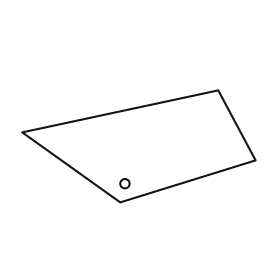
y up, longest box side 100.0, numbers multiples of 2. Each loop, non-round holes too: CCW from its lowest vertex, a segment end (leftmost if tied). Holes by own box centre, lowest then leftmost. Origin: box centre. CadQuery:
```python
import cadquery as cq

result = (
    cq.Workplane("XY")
    .moveTo(-8.0, -24.0)
    .lineTo(50.0, -6.0)
    .lineTo(34.0, 24.0)
    .lineTo(-50.0, 6.0)
    .close()
    .moveTo(-6.0, -16.0)
    .circle(2.0)
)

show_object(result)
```